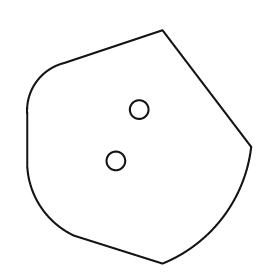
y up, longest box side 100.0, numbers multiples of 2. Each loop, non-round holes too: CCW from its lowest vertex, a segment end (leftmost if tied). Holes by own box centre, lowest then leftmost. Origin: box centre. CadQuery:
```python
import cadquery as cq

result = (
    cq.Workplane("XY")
    .moveTo(10.0, -50.0)
    .threePointArc((36.0, -30.0), (48.0, 0.0))
    .lineTo(10.0, 50.0)
    .lineTo(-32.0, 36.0)
    .threePointArc((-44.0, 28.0), (-48.0, 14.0))
    .lineTo(-48.0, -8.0)
    .threePointArc((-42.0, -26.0), (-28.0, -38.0))
    .close()
    .moveTo(-10.0, -6.0)
    .circle(4.0)
    .moveTo(0.0, 16.0)
    .circle(4.0)
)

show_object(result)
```